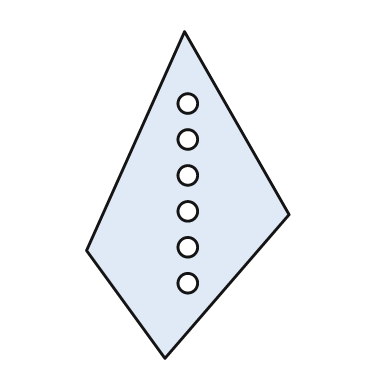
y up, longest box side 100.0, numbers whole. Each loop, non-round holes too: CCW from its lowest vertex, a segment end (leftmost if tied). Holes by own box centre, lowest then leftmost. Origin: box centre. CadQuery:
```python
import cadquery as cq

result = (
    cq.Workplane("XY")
    .moveTo(-7.0, -50.0)
    .lineTo(31.0, -6.0)
    .lineTo(-1.0, 50.0)
    .lineTo(-31.0, -17.0)
    .close()
    .moveTo(0.0, -27.0)
    .circle(3.0)
    .moveTo(0.0, -16.0)
    .circle(3.0)
    .moveTo(0.0, -5.0)
    .circle(3.0)
    .moveTo(0.0, 6.0)
    .circle(3.0)
    .moveTo(0.0, 17.0)
    .circle(3.0)
    .moveTo(0.0, 28.0)
    .circle(3.0)
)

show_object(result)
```